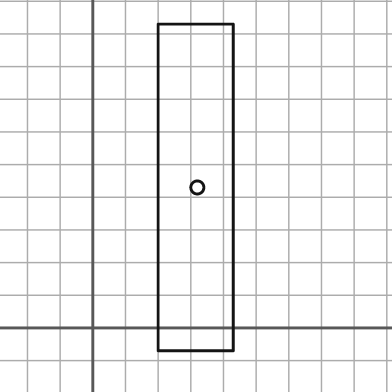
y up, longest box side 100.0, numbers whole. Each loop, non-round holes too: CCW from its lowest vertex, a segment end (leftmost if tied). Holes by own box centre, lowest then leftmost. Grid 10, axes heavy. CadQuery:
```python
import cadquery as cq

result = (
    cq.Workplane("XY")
    .moveTo(20.0, -7.0)
    .lineTo(43.0, -7.0)
    .lineTo(43.0, 93.0)
    .lineTo(20.0, 93.0)
    .close()
    .moveTo(32.0, 43.0)
    .circle(2.0)
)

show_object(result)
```